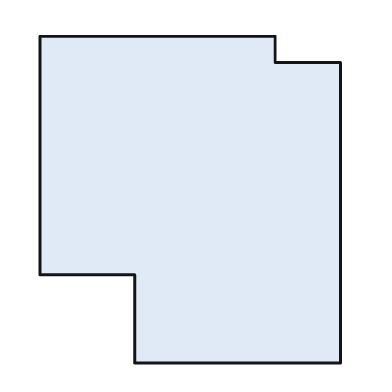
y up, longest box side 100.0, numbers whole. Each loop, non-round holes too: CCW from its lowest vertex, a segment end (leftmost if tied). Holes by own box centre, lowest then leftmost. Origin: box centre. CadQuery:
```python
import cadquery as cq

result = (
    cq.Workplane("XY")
    .moveTo(-17.0, -50.0)
    .lineTo(46.0, -50.0)
    .lineTo(46.0, 42.0)
    .lineTo(26.0, 42.0)
    .lineTo(26.0, 50.0)
    .lineTo(-46.0, 50.0)
    .lineTo(-46.0, -23.0)
    .lineTo(-17.0, -23.0)
    .close()
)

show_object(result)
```